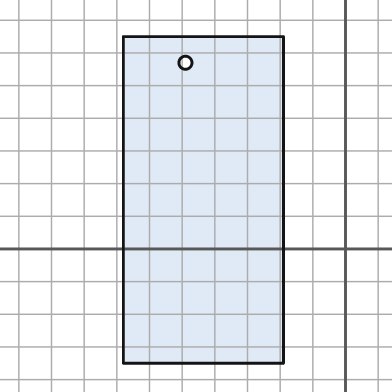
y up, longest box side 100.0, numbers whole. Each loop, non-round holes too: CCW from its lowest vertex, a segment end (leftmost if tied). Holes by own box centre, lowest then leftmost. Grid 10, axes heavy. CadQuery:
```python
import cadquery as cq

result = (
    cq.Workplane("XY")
    .moveTo(-68.0, -35.0)
    .lineTo(-19.0, -35.0)
    .lineTo(-19.0, 65.0)
    .lineTo(-68.0, 65.0)
    .close()
    .moveTo(-49.0, 57.0)
    .circle(2.0)
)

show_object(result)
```